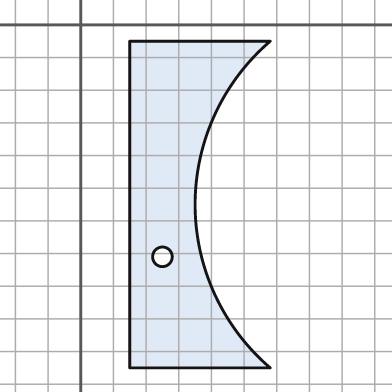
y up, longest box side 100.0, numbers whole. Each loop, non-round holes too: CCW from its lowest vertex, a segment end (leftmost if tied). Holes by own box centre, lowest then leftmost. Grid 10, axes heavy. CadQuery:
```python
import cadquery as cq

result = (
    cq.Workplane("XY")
    .moveTo(15.0, -105.0)
    .lineTo(58.0, -105.0)
    .threePointArc((35.0, -55.0), (58.0, -5.0))
    .lineTo(15.0, -5.0)
    .close()
    .moveTo(25.0, -71.0)
    .circle(3.0)
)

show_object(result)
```